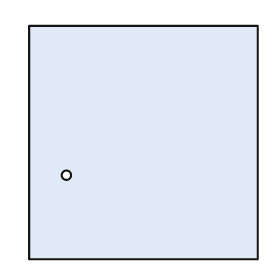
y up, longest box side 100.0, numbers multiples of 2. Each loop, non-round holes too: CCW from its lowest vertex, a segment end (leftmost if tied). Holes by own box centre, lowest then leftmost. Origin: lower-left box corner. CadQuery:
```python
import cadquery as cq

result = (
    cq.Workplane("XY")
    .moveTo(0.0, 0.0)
    .lineTo(98.0, 0.0)
    .lineTo(98.0, 100.0)
    .lineTo(0.0, 100.0)
    .close()
    .moveTo(16.0, 36.0)
    .circle(2.0)
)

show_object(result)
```